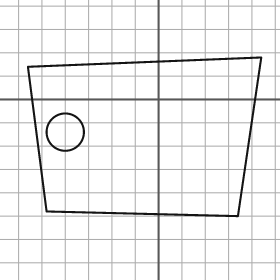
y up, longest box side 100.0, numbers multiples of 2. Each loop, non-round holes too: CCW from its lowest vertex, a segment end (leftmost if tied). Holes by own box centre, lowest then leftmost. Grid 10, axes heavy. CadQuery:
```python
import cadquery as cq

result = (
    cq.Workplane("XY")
    .moveTo(34.0, -50.0)
    .lineTo(44.0, 18.0)
    .lineTo(-56.0, 14.0)
    .lineTo(-48.0, -48.0)
    .close()
    .moveTo(-40.0, -14.0)
    .circle(8.0)
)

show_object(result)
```